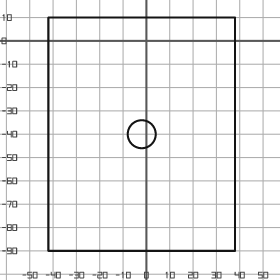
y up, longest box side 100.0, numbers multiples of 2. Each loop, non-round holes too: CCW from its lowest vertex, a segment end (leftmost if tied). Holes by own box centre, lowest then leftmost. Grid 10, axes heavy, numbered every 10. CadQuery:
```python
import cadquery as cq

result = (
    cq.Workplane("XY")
    .moveTo(-42.0, -90.0)
    .lineTo(38.0, -90.0)
    .lineTo(38.0, 10.0)
    .lineTo(-42.0, 10.0)
    .close()
    .moveTo(-2.0, -40.0)
    .circle(6.0)
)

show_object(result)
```